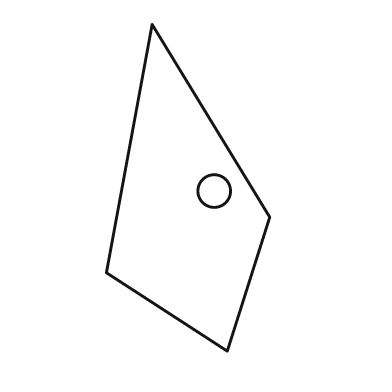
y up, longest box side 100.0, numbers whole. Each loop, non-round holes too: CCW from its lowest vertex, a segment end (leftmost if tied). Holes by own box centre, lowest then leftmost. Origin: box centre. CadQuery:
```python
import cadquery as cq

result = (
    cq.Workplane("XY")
    .moveTo(12.0, -50.0)
    .lineTo(25.0, -9.0)
    .lineTo(-11.0, 50.0)
    .lineTo(-25.0, -26.0)
    .close()
    .moveTo(8.0, -1.0)
    .circle(5.0)
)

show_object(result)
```